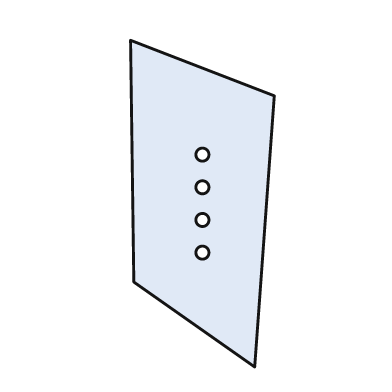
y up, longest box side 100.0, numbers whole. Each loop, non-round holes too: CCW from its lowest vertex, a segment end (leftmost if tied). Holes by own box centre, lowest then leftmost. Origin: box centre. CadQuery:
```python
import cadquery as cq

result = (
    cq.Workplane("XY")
    .moveTo(16.0, -50.0)
    .lineTo(22.0, 33.0)
    .lineTo(-22.0, 50.0)
    .lineTo(-21.0, -24.0)
    .close()
    .moveTo(0.0, -15.0)
    .circle(2.0)
    .moveTo(0.0, -5.0)
    .circle(2.0)
    .moveTo(0.0, 5.0)
    .circle(2.0)
    .moveTo(0.0, 15.0)
    .circle(2.0)
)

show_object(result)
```